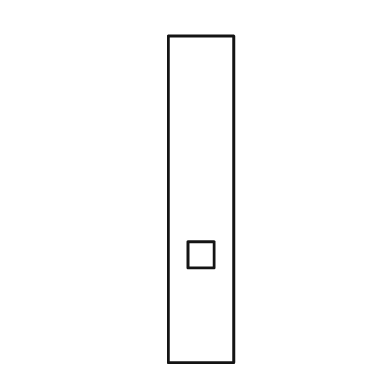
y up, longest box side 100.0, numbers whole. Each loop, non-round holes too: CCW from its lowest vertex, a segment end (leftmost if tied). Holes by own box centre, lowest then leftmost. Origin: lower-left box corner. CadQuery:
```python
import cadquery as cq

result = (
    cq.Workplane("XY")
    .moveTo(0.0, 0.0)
    .lineTo(20.0, 0.0)
    .lineTo(20.0, 100.0)
    .lineTo(0.0, 100.0)
    .close()
    .moveTo(6.0, 29.0)
    .lineTo(14.0, 29.0)
    .lineTo(14.0, 37.0)
    .lineTo(6.0, 37.0)
    .close()
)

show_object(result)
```